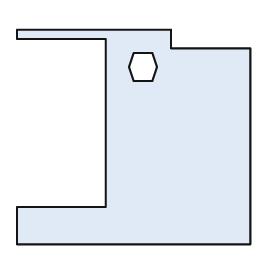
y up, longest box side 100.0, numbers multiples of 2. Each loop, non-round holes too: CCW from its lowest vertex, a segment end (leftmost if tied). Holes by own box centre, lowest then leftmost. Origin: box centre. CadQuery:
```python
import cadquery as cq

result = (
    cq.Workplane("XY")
    .moveTo(-50.0, -46.0)
    .lineTo(50.0, -46.0)
    .lineTo(50.0, 38.0)
    .lineTo(16.0, 38.0)
    .lineTo(16.0, 46.0)
    .lineTo(-50.0, 46.0)
    .lineTo(-50.0, 42.0)
    .lineTo(-12.0, 42.0)
    .lineTo(-12.0, -30.0)
    .lineTo(-50.0, -30.0)
    .close()
    .moveTo(0.0, 24.0)
    .lineTo(8.0, 24.0)
    .lineTo(10.0, 30.0)
    .lineTo(8.0, 36.0)
    .lineTo(0.0, 36.0)
    .lineTo(-2.0, 30.0)
    .close()
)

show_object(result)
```